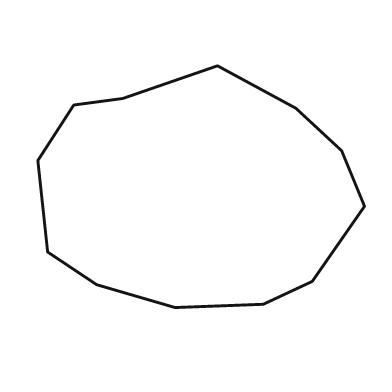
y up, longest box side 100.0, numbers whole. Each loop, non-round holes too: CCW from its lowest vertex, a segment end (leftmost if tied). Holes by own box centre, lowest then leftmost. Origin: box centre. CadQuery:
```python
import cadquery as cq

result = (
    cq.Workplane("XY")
    .moveTo(-8.0, -37.0)
    .lineTo(19.0, -36.0)
    .lineTo(34.0, -29.0)
    .lineTo(50.0, -6.0)
    .lineTo(43.0, 11.0)
    .lineTo(29.0, 24.0)
    .lineTo(5.0, 37.0)
    .lineTo(-24.0, 27.0)
    .lineTo(-39.0, 25.0)
    .lineTo(-50.0, 8.0)
    .lineTo(-47.0, -20.0)
    .lineTo(-32.0, -30.0)
    .close()
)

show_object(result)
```